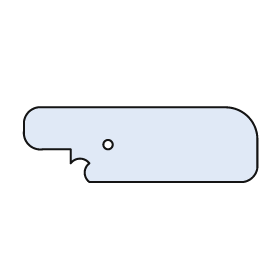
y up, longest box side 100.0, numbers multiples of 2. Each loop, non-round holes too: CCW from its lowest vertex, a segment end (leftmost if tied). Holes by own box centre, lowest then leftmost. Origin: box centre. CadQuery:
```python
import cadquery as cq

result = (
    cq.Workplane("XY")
    .moveTo(-22.0, -16.0)
    .lineTo(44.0, -16.0)
    .threePointArc((48.0, -14.0), (50.0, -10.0))
    .lineTo(50.0, 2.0)
    .threePointArc((46.0, 12.0), (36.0, 16.0))
    .lineTo(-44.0, 16.0)
    .threePointArc((-48.0, 14.0), (-50.0, 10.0))
    .lineTo(-50.0, 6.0)
    .threePointArc((-48.0, 0.0), (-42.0, -2.0))
    .lineTo(-30.0, -2.0)
    .lineTo(-30.0, -8.0)
    .threePointArc((-26.0, -6.0), (-22.0, -8.0))
    .threePointArc((-24.0, -12.0), (-22.0, -16.0))
    .close()
    .moveTo(-14.0, 0.0)
    .circle(2.0)
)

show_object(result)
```